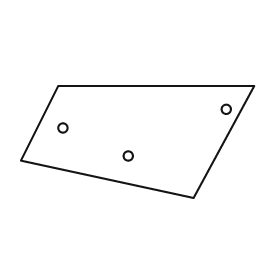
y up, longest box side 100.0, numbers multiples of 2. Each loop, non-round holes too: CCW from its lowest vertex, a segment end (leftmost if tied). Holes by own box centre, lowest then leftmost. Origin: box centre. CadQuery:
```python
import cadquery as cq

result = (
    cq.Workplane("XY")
    .moveTo(24.0, -24.0)
    .lineTo(50.0, 24.0)
    .lineTo(-34.0, 24.0)
    .lineTo(-50.0, -8.0)
    .close()
    .moveTo(-4.0, -6.0)
    .circle(2.0)
    .moveTo(-32.0, 6.0)
    .circle(2.0)
    .moveTo(38.0, 14.0)
    .circle(2.0)
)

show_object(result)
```